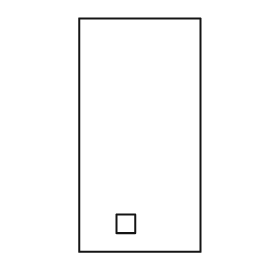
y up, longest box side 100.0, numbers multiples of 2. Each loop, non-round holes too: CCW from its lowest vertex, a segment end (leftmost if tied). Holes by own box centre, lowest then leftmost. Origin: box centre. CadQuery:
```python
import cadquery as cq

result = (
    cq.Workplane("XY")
    .moveTo(-26.0, -50.0)
    .lineTo(26.0, -50.0)
    .lineTo(26.0, 50.0)
    .lineTo(-26.0, 50.0)
    .close()
    .moveTo(-10.0, -42.0)
    .lineTo(-2.0, -42.0)
    .lineTo(-2.0, -34.0)
    .lineTo(-10.0, -34.0)
    .close()
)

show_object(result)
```